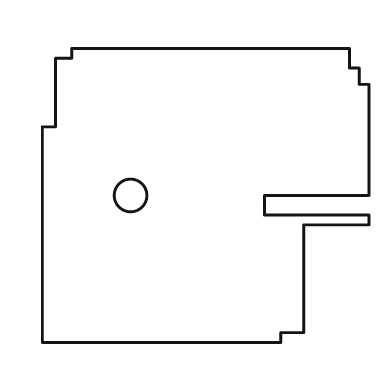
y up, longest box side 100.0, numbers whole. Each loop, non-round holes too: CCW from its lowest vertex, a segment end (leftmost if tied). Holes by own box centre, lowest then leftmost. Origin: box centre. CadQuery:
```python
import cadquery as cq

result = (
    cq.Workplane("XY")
    .moveTo(-50.0, -45.0)
    .lineTo(23.0, -45.0)
    .lineTo(23.0, -42.0)
    .lineTo(30.0, -42.0)
    .lineTo(30.0, -9.0)
    .lineTo(50.0, -9.0)
    .lineTo(50.0, -6.0)
    .lineTo(18.0, -6.0)
    .lineTo(18.0, 0.0)
    .lineTo(50.0, 0.0)
    .lineTo(50.0, 34.0)
    .lineTo(47.0, 34.0)
    .lineTo(47.0, 39.0)
    .lineTo(44.0, 39.0)
    .lineTo(44.0, 45.0)
    .lineTo(-41.0, 45.0)
    .lineTo(-41.0, 42.0)
    .lineTo(-46.0, 42.0)
    .lineTo(-46.0, 21.0)
    .lineTo(-50.0, 21.0)
    .close()
    .moveTo(-23.0, 0.0)
    .circle(5.0)
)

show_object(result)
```